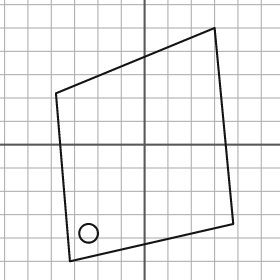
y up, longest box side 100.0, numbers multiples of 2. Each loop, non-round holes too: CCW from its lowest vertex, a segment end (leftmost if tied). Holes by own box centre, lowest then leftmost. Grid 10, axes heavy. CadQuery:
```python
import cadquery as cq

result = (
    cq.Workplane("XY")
    .moveTo(-32.0, -50.0)
    .lineTo(38.0, -34.0)
    .lineTo(30.0, 50.0)
    .lineTo(-38.0, 22.0)
    .close()
    .moveTo(-24.0, -38.0)
    .circle(4.0)
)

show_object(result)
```